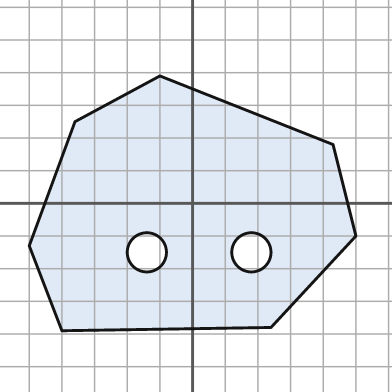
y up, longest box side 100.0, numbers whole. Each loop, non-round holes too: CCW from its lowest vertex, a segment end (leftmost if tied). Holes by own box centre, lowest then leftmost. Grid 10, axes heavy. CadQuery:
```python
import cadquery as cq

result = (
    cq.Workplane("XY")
    .moveTo(-40.0, -39.0)
    .lineTo(24.0, -38.0)
    .lineTo(50.0, -10.0)
    .lineTo(43.0, 18.0)
    .lineTo(-10.0, 39.0)
    .lineTo(-36.0, 25.0)
    .lineTo(-50.0, -13.0)
    .close()
    .moveTo(-14.0, -15.0)
    .circle(6.0)
    .moveTo(18.0, -15.0)
    .circle(6.0)
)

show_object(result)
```